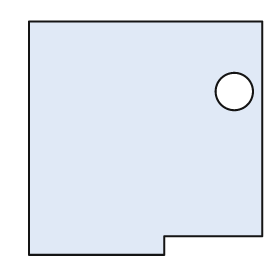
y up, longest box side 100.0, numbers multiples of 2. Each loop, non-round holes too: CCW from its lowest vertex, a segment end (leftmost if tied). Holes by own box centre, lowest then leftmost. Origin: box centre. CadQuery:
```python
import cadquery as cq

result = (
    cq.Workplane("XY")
    .moveTo(-50.0, -50.0)
    .lineTo(8.0, -50.0)
    .lineTo(8.0, -42.0)
    .lineTo(50.0, -42.0)
    .lineTo(50.0, 50.0)
    .lineTo(-50.0, 50.0)
    .close()
    .moveTo(38.0, 20.0)
    .circle(8.0)
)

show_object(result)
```